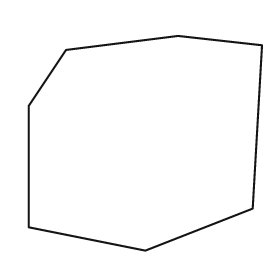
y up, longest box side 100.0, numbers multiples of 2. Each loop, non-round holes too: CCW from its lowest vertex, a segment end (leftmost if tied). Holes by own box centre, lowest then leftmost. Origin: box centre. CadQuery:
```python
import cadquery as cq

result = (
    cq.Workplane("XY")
    .moveTo(0.0, -46.0)
    .lineTo(46.0, -28.0)
    .lineTo(50.0, 42.0)
    .lineTo(14.0, 46.0)
    .lineTo(-34.0, 40.0)
    .lineTo(-50.0, 16.0)
    .lineTo(-50.0, -36.0)
    .close()
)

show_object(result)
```